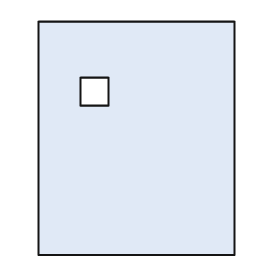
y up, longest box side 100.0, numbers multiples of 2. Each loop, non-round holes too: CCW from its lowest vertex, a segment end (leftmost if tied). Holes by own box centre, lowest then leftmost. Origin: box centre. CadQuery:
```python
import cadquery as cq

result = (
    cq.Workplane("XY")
    .moveTo(-42.0, -50.0)
    .lineTo(42.0, -50.0)
    .lineTo(42.0, 50.0)
    .lineTo(-42.0, 50.0)
    .close()
    .moveTo(-24.0, 14.0)
    .lineTo(-12.0, 14.0)
    .lineTo(-12.0, 26.0)
    .lineTo(-24.0, 26.0)
    .close()
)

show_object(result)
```